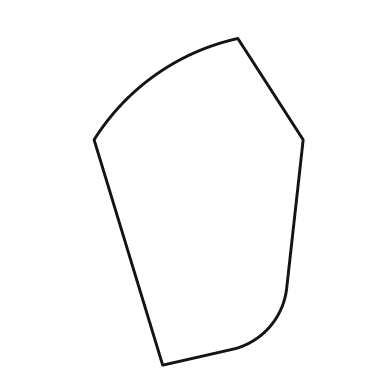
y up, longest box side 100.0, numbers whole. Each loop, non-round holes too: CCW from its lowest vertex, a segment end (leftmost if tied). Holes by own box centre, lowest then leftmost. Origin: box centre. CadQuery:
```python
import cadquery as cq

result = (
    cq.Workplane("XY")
    .moveTo(-11.0, -50.0)
    .lineTo(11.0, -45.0)
    .threePointArc((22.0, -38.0), (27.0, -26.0))
    .lineTo(32.0, 19.0)
    .lineTo(12.0, 50.0)
    .threePointArc((-13.0, 39.0), (-32.0, 19.0))
    .close()
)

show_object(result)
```